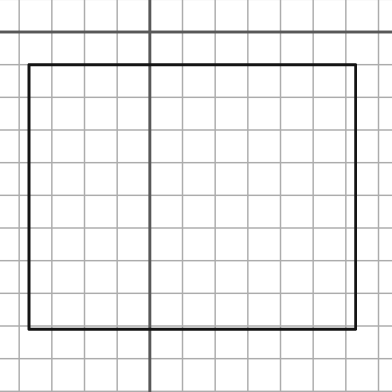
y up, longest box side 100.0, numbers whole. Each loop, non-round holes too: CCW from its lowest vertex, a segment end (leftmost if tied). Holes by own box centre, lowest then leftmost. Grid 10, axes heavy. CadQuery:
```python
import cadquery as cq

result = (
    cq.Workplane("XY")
    .moveTo(-37.0, -91.0)
    .lineTo(63.0, -91.0)
    .lineTo(63.0, -10.0)
    .lineTo(-37.0, -10.0)
    .close()
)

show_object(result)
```